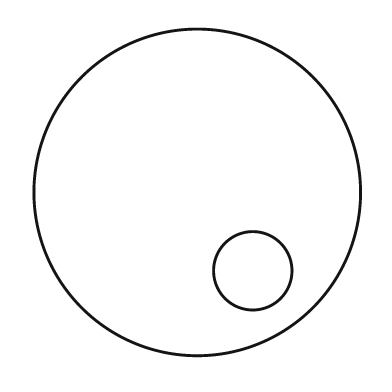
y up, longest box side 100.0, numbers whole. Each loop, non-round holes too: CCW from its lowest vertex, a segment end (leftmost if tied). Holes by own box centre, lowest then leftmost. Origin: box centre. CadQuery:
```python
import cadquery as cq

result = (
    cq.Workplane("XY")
    .moveTo(0.0, 0.0)
    .circle(50.0)
    .moveTo(17.0, -24.0)
    .circle(12.0)
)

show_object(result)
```